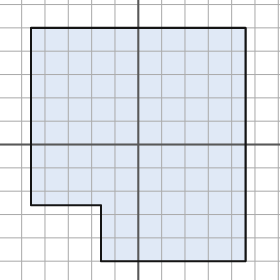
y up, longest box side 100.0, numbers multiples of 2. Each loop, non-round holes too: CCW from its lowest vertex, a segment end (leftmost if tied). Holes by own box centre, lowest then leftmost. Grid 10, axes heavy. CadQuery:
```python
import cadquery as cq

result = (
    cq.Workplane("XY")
    .moveTo(-16.0, -50.0)
    .lineTo(46.0, -50.0)
    .lineTo(46.0, 50.0)
    .lineTo(-46.0, 50.0)
    .lineTo(-46.0, -26.0)
    .lineTo(-16.0, -26.0)
    .close()
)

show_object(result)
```